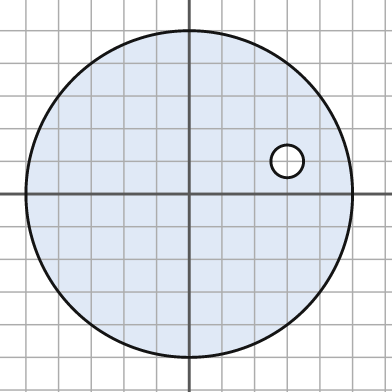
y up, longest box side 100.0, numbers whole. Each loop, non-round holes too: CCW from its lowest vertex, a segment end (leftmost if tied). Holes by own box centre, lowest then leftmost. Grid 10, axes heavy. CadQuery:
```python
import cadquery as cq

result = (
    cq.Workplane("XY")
    .moveTo(0.0, 0.0)
    .circle(50.0)
    .moveTo(30.0, 10.0)
    .circle(5.0)
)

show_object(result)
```